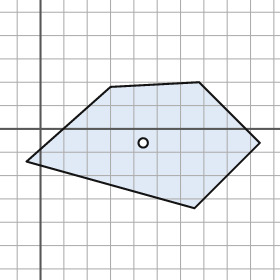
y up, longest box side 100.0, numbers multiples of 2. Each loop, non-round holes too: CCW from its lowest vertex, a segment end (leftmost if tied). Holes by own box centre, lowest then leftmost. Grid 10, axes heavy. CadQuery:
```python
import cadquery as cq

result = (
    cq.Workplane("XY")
    .moveTo(66.0, -34.0)
    .lineTo(94.0, -6.0)
    .lineTo(68.0, 20.0)
    .lineTo(30.0, 18.0)
    .lineTo(-6.0, -14.0)
    .close()
    .moveTo(44.0, -6.0)
    .circle(2.0)
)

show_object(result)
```